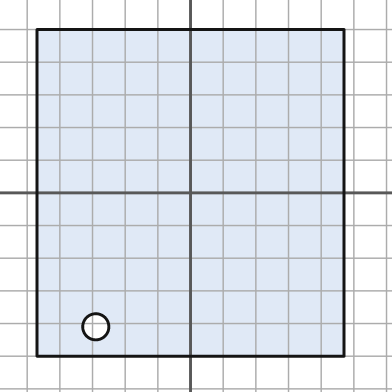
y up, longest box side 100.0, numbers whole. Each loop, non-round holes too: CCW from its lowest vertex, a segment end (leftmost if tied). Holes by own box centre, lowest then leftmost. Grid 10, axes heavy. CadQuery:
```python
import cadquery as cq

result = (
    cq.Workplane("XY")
    .moveTo(-47.0, -50.0)
    .lineTo(47.0, -50.0)
    .lineTo(47.0, 50.0)
    .lineTo(-47.0, 50.0)
    .close()
    .moveTo(-29.0, -41.0)
    .circle(4.0)
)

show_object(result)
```